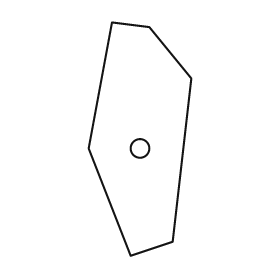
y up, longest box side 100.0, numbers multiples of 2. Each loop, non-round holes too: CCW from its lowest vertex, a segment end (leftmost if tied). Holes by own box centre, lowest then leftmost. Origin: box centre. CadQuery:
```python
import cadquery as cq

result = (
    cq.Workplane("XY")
    .moveTo(-4.0, -50.0)
    .lineTo(14.0, -44.0)
    .lineTo(22.0, 26.0)
    .lineTo(4.0, 48.0)
    .lineTo(-12.0, 50.0)
    .lineTo(-22.0, -4.0)
    .close()
    .moveTo(0.0, -4.0)
    .circle(4.0)
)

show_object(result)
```